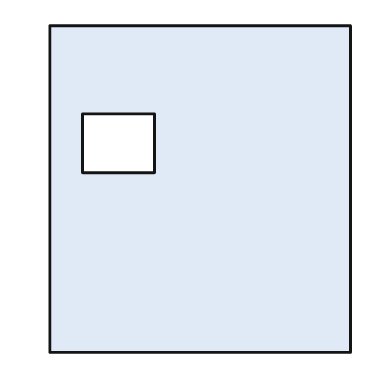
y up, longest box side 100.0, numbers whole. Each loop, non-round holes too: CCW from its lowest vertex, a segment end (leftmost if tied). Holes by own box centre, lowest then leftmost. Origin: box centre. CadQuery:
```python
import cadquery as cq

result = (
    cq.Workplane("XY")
    .moveTo(-46.0, -50.0)
    .lineTo(46.0, -50.0)
    .lineTo(46.0, 50.0)
    .lineTo(-46.0, 50.0)
    .close()
    .moveTo(-36.0, 5.0)
    .lineTo(-14.0, 5.0)
    .lineTo(-14.0, 23.0)
    .lineTo(-36.0, 23.0)
    .close()
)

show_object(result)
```